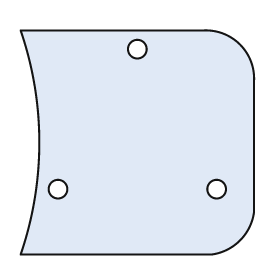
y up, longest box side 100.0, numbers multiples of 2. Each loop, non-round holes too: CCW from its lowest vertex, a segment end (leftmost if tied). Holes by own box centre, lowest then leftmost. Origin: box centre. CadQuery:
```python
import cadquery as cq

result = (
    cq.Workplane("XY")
    .moveTo(-50.0, -48.0)
    .lineTo(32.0, -48.0)
    .threePointArc((44.0, -42.0), (50.0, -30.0))
    .lineTo(50.0, 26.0)
    .threePointArc((44.0, 42.0), (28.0, 48.0))
    .lineTo(-50.0, 48.0)
    .threePointArc((-42.0, 0.0), (-50.0, -48.0))
    .close()
    .moveTo(-34.0, -20.0)
    .circle(4.0)
    .moveTo(34.0, -20.0)
    .circle(4.0)
    .moveTo(0.0, 40.0)
    .circle(4.0)
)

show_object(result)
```